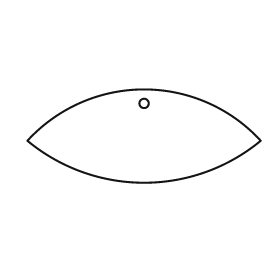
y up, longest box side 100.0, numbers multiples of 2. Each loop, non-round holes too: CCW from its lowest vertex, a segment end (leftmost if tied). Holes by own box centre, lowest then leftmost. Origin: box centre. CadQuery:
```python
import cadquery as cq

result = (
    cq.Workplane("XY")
    .moveTo(-50.0, -2.0)
    .threePointArc((0.0, -20.0), (50.0, -2.0))
    .threePointArc((0.0, 20.0), (-50.0, -2.0))
    .close()
    .moveTo(0.0, 14.0)
    .circle(2.0)
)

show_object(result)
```